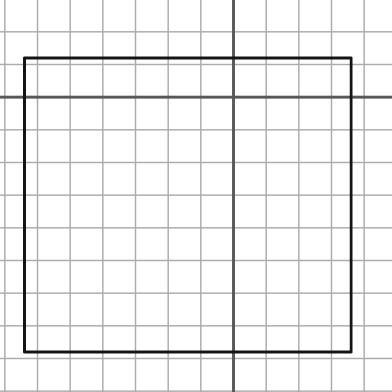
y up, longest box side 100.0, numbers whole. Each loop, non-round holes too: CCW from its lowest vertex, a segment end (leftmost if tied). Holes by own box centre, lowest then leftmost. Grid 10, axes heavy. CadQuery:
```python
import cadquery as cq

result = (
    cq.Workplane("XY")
    .moveTo(-64.0, -78.0)
    .lineTo(36.0, -78.0)
    .lineTo(36.0, 12.0)
    .lineTo(-64.0, 12.0)
    .close()
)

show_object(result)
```